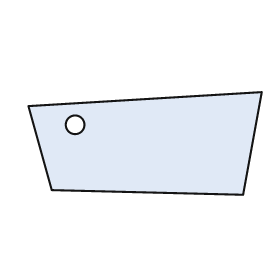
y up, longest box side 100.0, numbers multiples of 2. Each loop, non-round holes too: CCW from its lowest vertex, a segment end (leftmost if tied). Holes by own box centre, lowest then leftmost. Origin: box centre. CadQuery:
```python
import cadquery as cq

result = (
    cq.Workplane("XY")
    .moveTo(42.0, -22.0)
    .lineTo(50.0, 22.0)
    .lineTo(-50.0, 16.0)
    .lineTo(-40.0, -20.0)
    .close()
    .moveTo(-30.0, 8.0)
    .circle(4.0)
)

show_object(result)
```